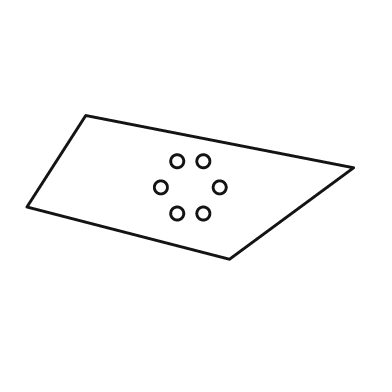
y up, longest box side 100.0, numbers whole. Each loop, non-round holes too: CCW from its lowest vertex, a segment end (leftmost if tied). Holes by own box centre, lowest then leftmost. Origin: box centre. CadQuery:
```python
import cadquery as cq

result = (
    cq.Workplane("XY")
    .moveTo(12.0, -22.0)
    .lineTo(50.0, 6.0)
    .lineTo(-32.0, 22.0)
    .lineTo(-50.0, -6.0)
    .close()
    .moveTo(-4.0, -8.0)
    .circle(2.0)
    .moveTo(4.0, -8.0)
    .circle(2.0)
    .moveTo(-9.0, 0.0)
    .circle(2.0)
    .moveTo(9.0, 0.0)
    .circle(2.0)
    .moveTo(-4.0, 8.0)
    .circle(2.0)
    .moveTo(4.0, 8.0)
    .circle(2.0)
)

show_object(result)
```